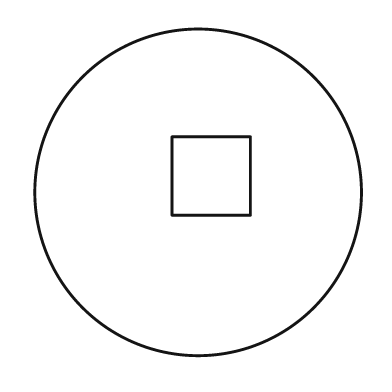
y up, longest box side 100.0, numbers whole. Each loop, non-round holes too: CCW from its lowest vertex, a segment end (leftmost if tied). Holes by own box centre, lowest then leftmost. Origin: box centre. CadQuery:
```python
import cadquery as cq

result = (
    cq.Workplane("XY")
    .moveTo(0.0, 0.0)
    .circle(50.0)
    .moveTo(-8.0, -7.0)
    .lineTo(16.0, -7.0)
    .lineTo(16.0, 17.0)
    .lineTo(-8.0, 17.0)
    .close()
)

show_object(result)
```